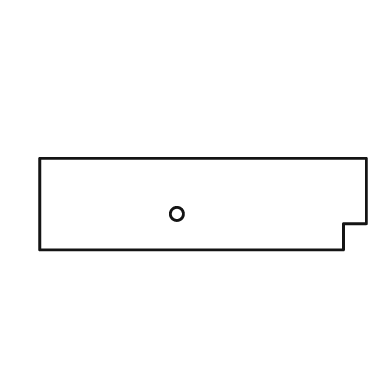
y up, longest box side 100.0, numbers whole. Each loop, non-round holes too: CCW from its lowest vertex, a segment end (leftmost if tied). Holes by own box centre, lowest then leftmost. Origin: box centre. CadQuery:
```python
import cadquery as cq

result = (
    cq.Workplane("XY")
    .moveTo(-50.0, -14.0)
    .lineTo(43.0, -14.0)
    .lineTo(43.0, -6.0)
    .lineTo(50.0, -6.0)
    .lineTo(50.0, 14.0)
    .lineTo(-50.0, 14.0)
    .close()
    .moveTo(-8.0, -3.0)
    .circle(2.0)
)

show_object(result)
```